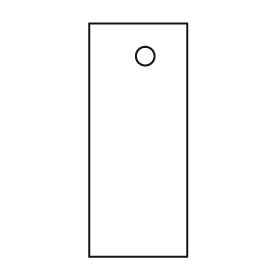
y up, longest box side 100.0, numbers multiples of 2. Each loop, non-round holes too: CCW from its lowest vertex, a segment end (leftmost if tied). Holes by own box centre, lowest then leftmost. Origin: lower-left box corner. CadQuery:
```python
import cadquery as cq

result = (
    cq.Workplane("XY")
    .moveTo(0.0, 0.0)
    .lineTo(42.0, 0.0)
    .lineTo(42.0, 100.0)
    .lineTo(0.0, 100.0)
    .close()
    .moveTo(24.0, 86.0)
    .circle(4.0)
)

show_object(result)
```